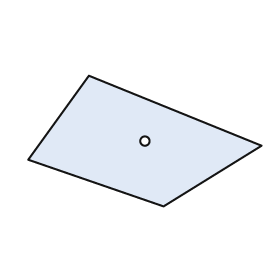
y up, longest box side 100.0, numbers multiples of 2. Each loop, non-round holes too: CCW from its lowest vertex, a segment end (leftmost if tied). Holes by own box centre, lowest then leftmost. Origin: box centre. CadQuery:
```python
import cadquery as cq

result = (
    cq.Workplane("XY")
    .moveTo(8.0, -28.0)
    .lineTo(50.0, -2.0)
    .lineTo(-24.0, 28.0)
    .lineTo(-50.0, -8.0)
    .close()
    .moveTo(0.0, 0.0)
    .circle(2.0)
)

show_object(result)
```